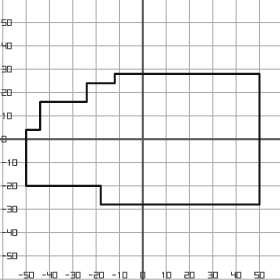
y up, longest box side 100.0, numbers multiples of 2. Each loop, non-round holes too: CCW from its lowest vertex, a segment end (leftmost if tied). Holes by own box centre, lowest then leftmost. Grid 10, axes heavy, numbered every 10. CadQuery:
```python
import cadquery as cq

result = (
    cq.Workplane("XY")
    .moveTo(-18.0, -28.0)
    .lineTo(50.0, -28.0)
    .lineTo(50.0, 28.0)
    .lineTo(-12.0, 28.0)
    .lineTo(-12.0, 24.0)
    .lineTo(-24.0, 24.0)
    .lineTo(-24.0, 16.0)
    .lineTo(-44.0, 16.0)
    .lineTo(-44.0, 4.0)
    .lineTo(-50.0, 4.0)
    .lineTo(-50.0, -20.0)
    .lineTo(-18.0, -20.0)
    .close()
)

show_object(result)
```